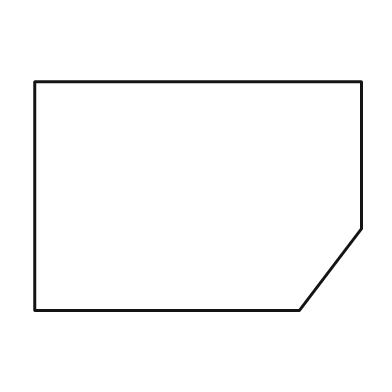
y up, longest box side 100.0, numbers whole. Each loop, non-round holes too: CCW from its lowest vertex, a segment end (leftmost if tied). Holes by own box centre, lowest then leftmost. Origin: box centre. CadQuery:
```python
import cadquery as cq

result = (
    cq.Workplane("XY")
    .moveTo(-50.0, -35.0)
    .lineTo(31.0, -35.0)
    .lineTo(50.0, -10.0)
    .lineTo(50.0, 35.0)
    .lineTo(-50.0, 35.0)
    .close()
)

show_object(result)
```